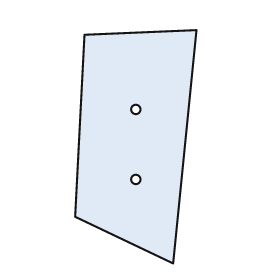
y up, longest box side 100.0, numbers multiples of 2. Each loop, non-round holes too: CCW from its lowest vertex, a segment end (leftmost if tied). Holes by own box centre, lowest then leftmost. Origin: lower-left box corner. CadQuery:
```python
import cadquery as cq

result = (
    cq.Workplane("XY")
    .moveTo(42.0, 0.0)
    .lineTo(52.0, 100.0)
    .lineTo(4.0, 98.0)
    .lineTo(0.0, 20.0)
    .close()
    .moveTo(26.0, 36.0)
    .circle(2.0)
    .moveTo(26.0, 66.0)
    .circle(2.0)
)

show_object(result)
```